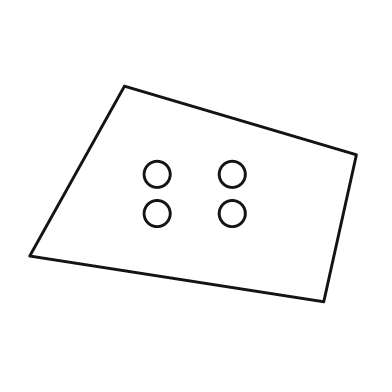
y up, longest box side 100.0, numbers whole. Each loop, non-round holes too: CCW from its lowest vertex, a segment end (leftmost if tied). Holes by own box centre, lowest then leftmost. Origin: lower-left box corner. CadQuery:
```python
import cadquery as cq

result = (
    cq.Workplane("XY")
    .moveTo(90.0, 0.0)
    .lineTo(100.0, 45.0)
    .lineTo(29.0, 66.0)
    .lineTo(0.0, 14.0)
    .close()
    .moveTo(39.0, 27.0)
    .circle(4.0)
    .moveTo(62.0, 27.0)
    .circle(4.0)
    .moveTo(39.0, 39.0)
    .circle(4.0)
    .moveTo(62.0, 39.0)
    .circle(4.0)
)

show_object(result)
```